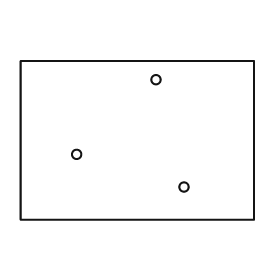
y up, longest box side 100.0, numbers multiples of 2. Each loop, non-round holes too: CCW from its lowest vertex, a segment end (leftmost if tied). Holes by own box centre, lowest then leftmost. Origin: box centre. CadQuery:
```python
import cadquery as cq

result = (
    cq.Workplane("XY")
    .moveTo(-50.0, -34.0)
    .lineTo(50.0, -34.0)
    .lineTo(50.0, 34.0)
    .lineTo(-50.0, 34.0)
    .close()
    .moveTo(20.0, -20.0)
    .circle(2.0)
    .moveTo(-26.0, -6.0)
    .circle(2.0)
    .moveTo(8.0, 26.0)
    .circle(2.0)
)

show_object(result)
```